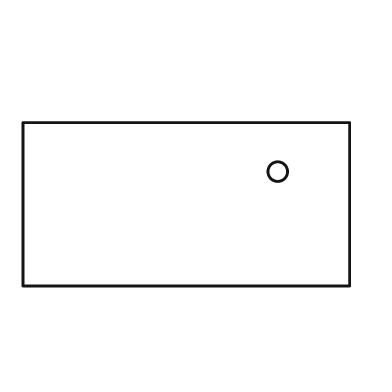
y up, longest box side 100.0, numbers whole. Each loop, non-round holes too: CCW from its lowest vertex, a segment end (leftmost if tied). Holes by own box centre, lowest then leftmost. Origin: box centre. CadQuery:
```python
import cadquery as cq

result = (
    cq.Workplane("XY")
    .moveTo(-50.0, -25.0)
    .lineTo(50.0, -25.0)
    .lineTo(50.0, 25.0)
    .lineTo(-50.0, 25.0)
    .close()
    .moveTo(28.0, 10.0)
    .circle(3.0)
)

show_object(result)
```